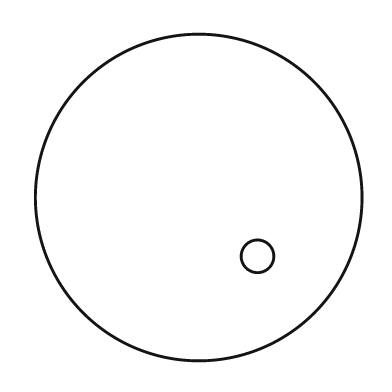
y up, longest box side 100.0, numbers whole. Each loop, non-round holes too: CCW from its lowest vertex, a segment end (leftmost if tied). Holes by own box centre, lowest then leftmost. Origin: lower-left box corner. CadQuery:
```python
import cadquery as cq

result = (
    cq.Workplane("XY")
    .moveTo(50.0, 50.0)
    .circle(50.0)
    .moveTo(68.0, 32.0)
    .circle(5.0)
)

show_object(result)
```